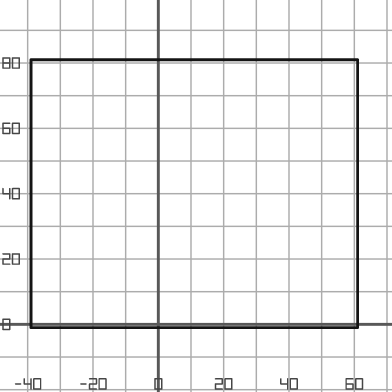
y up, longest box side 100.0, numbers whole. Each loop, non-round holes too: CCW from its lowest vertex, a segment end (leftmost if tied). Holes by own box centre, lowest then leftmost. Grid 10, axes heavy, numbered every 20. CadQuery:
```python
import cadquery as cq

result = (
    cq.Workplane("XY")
    .moveTo(-39.0, -1.0)
    .lineTo(61.0, -1.0)
    .lineTo(61.0, 81.0)
    .lineTo(-39.0, 81.0)
    .close()
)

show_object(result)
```